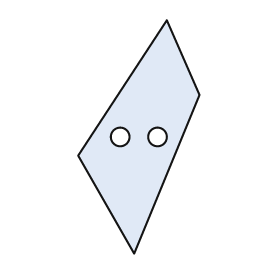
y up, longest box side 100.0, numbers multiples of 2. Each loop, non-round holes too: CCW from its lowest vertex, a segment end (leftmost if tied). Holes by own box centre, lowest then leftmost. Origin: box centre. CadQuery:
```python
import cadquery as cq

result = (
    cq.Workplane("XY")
    .moveTo(-2.0, -50.0)
    .lineTo(26.0, 18.0)
    .lineTo(12.0, 50.0)
    .lineTo(-26.0, -8.0)
    .close()
    .moveTo(-8.0, 0.0)
    .circle(4.0)
    .moveTo(8.0, 0.0)
    .circle(4.0)
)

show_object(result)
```